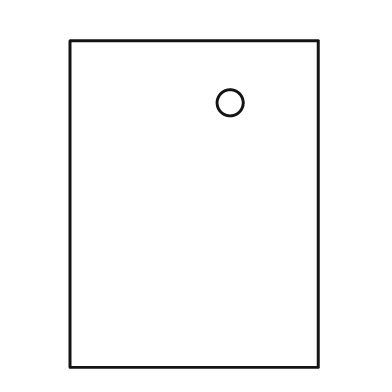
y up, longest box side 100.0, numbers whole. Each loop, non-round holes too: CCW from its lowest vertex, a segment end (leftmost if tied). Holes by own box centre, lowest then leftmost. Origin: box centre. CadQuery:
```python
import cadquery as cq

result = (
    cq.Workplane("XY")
    .moveTo(-38.0, -50.0)
    .lineTo(38.0, -50.0)
    .lineTo(38.0, 50.0)
    .lineTo(-38.0, 50.0)
    .close()
    .moveTo(11.0, 31.0)
    .circle(4.0)
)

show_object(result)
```